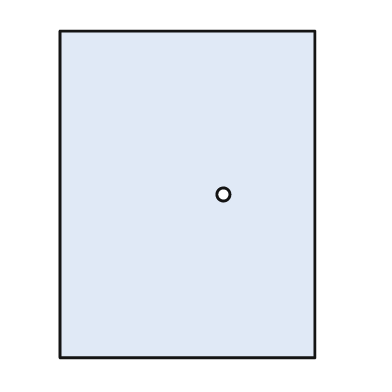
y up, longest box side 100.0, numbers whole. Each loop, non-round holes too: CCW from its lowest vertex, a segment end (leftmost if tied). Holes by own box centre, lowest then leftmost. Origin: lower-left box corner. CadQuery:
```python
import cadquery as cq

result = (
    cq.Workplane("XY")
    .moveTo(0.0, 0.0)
    .lineTo(78.0, 0.0)
    .lineTo(78.0, 100.0)
    .lineTo(0.0, 100.0)
    .close()
    .moveTo(50.0, 50.0)
    .circle(2.0)
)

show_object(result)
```